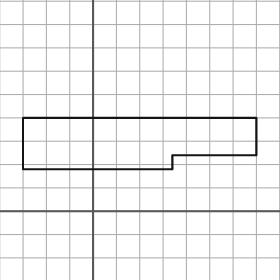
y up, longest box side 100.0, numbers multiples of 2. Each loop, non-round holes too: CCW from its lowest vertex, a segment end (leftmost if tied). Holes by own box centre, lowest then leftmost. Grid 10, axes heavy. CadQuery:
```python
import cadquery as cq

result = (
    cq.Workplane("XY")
    .moveTo(-30.0, 18.0)
    .lineTo(34.0, 18.0)
    .lineTo(34.0, 24.0)
    .lineTo(70.0, 24.0)
    .lineTo(70.0, 40.0)
    .lineTo(-30.0, 40.0)
    .close()
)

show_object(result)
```